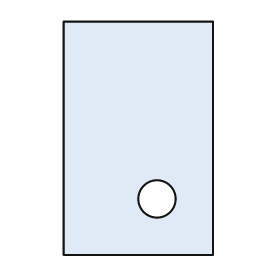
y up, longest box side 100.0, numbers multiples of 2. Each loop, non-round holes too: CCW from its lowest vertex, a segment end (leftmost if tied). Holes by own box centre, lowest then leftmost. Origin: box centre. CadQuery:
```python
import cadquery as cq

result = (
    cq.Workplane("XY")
    .moveTo(-32.0, -50.0)
    .lineTo(32.0, -50.0)
    .lineTo(32.0, 50.0)
    .lineTo(-32.0, 50.0)
    .close()
    .moveTo(8.0, -26.0)
    .circle(8.0)
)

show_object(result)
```